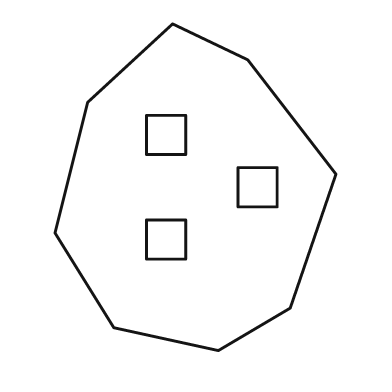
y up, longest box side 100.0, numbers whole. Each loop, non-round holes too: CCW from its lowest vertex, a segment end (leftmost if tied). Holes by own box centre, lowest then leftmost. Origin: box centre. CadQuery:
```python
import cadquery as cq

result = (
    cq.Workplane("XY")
    .moveTo(7.0, -50.0)
    .lineTo(29.0, -37.0)
    .lineTo(43.0, 4.0)
    .lineTo(16.0, 39.0)
    .lineTo(-7.0, 50.0)
    .lineTo(-33.0, 26.0)
    .lineTo(-43.0, -14.0)
    .lineTo(-25.0, -43.0)
    .close()
    .moveTo(-15.0, -22.0)
    .lineTo(-3.0, -22.0)
    .lineTo(-3.0, -10.0)
    .lineTo(-15.0, -10.0)
    .close()
    .moveTo(13.0, -6.0)
    .lineTo(25.0, -6.0)
    .lineTo(25.0, 6.0)
    .lineTo(13.0, 6.0)
    .close()
    .moveTo(-15.0, 10.0)
    .lineTo(-3.0, 10.0)
    .lineTo(-3.0, 22.0)
    .lineTo(-15.0, 22.0)
    .close()
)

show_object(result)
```